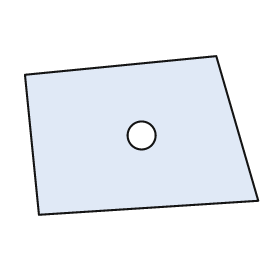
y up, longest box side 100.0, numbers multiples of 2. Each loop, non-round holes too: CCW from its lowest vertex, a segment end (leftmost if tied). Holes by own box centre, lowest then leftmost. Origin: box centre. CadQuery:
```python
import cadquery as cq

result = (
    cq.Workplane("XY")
    .moveTo(-44.0, -34.0)
    .lineTo(50.0, -28.0)
    .lineTo(32.0, 34.0)
    .lineTo(-50.0, 26.0)
    .close()
    .moveTo(0.0, 0.0)
    .circle(6.0)
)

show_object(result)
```